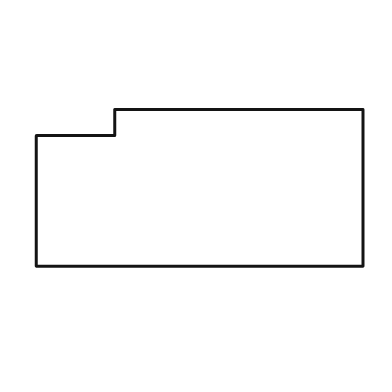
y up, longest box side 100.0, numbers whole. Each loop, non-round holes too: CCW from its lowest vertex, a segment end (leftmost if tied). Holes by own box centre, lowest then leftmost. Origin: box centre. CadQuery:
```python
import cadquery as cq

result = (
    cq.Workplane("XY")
    .moveTo(-50.0, -24.0)
    .lineTo(50.0, -24.0)
    .lineTo(50.0, 24.0)
    .lineTo(-26.0, 24.0)
    .lineTo(-26.0, 16.0)
    .lineTo(-50.0, 16.0)
    .close()
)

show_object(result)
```